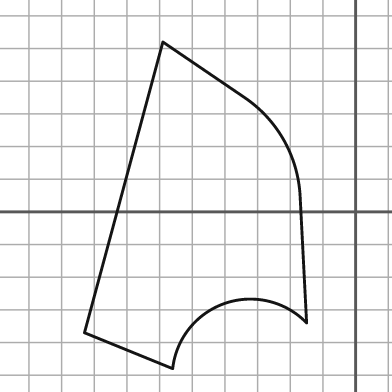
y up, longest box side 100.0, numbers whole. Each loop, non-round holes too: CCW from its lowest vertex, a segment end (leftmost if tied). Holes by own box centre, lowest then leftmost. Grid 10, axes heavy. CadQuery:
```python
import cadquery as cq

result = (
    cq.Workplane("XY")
    .moveTo(-56.0, -48.0)
    .threePointArc((-40.0, -28.0), (-15.0, -34.0))
    .lineTo(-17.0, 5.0)
    .threePointArc((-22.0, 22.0), (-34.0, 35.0))
    .lineTo(-59.0, 52.0)
    .lineTo(-83.0, -37.0)
    .close()
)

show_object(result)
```